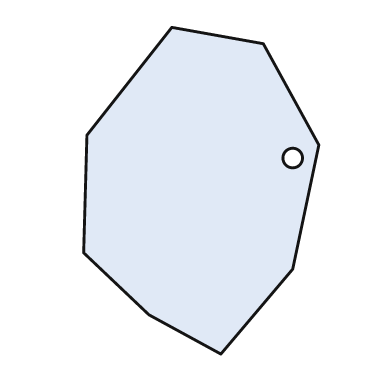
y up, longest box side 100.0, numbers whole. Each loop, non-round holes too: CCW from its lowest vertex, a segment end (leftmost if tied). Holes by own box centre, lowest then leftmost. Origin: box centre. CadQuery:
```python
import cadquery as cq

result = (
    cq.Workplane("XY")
    .moveTo(6.0, -50.0)
    .lineTo(28.0, -24.0)
    .lineTo(36.0, 14.0)
    .lineTo(19.0, 45.0)
    .lineTo(-9.0, 50.0)
    .lineTo(-35.0, 17.0)
    .lineTo(-36.0, -19.0)
    .lineTo(-16.0, -38.0)
    .close()
    .moveTo(28.0, 10.0)
    .circle(3.0)
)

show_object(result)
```